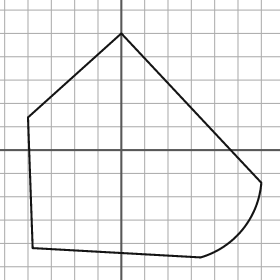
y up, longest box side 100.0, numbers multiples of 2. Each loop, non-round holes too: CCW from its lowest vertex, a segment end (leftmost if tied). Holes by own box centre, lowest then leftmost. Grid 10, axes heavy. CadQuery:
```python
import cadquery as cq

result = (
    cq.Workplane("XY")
    .moveTo(34.0, -46.0)
    .threePointArc((52.0, -34.0), (60.0, -14.0))
    .lineTo(0.0, 50.0)
    .lineTo(-40.0, 14.0)
    .lineTo(-38.0, -42.0)
    .close()
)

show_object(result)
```